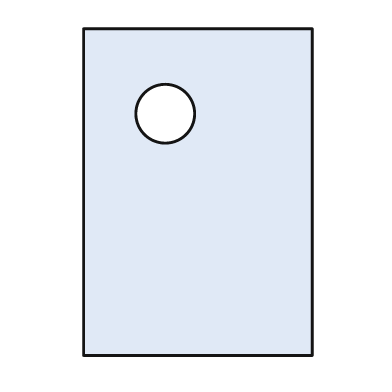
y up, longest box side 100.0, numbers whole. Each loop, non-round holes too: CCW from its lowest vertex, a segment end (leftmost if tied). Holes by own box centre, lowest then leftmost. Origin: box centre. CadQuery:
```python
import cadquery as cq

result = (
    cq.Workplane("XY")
    .moveTo(-35.0, -50.0)
    .lineTo(35.0, -50.0)
    .lineTo(35.0, 50.0)
    .lineTo(-35.0, 50.0)
    .close()
    .moveTo(-10.0, 24.0)
    .circle(9.0)
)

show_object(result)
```